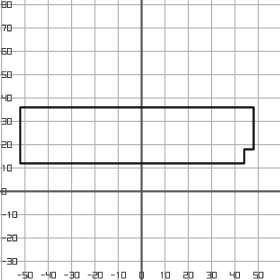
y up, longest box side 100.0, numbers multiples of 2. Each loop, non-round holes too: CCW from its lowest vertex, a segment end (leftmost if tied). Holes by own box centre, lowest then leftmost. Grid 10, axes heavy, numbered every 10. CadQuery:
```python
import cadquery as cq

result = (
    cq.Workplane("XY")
    .moveTo(-52.0, 12.0)
    .lineTo(44.0, 12.0)
    .lineTo(44.0, 18.0)
    .lineTo(48.0, 18.0)
    .lineTo(48.0, 36.0)
    .lineTo(-52.0, 36.0)
    .close()
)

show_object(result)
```